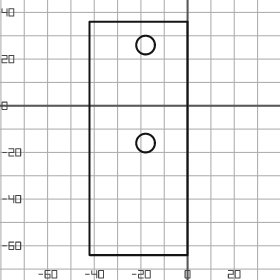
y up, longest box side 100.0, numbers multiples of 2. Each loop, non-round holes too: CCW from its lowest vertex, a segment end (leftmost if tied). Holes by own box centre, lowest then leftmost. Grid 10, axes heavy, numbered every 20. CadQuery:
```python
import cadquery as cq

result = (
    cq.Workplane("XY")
    .moveTo(-42.0, -64.0)
    .lineTo(0.0, -64.0)
    .lineTo(0.0, 36.0)
    .lineTo(-42.0, 36.0)
    .close()
    .moveTo(-18.0, -16.0)
    .circle(4.0)
    .moveTo(-18.0, 26.0)
    .circle(4.0)
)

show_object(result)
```